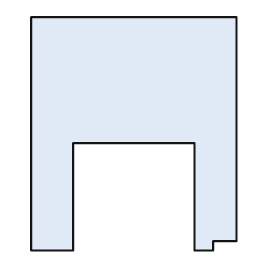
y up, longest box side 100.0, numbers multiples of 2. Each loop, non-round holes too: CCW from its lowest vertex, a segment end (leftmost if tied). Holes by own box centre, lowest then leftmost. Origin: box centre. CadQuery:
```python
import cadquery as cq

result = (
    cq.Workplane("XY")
    .moveTo(-44.0, -50.0)
    .lineTo(-26.0, -50.0)
    .lineTo(-26.0, -4.0)
    .lineTo(26.0, -4.0)
    .lineTo(26.0, -50.0)
    .lineTo(34.0, -50.0)
    .lineTo(34.0, -46.0)
    .lineTo(44.0, -46.0)
    .lineTo(44.0, 50.0)
    .lineTo(-44.0, 50.0)
    .close()
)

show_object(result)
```